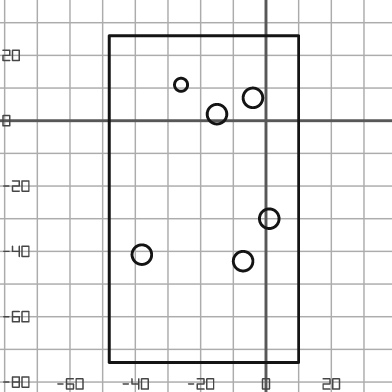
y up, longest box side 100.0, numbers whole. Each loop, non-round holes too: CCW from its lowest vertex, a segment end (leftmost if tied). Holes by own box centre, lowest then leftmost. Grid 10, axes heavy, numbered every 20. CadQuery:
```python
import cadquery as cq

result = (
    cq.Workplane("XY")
    .moveTo(-48.0, -74.0)
    .lineTo(10.0, -74.0)
    .lineTo(10.0, 26.0)
    .lineTo(-48.0, 26.0)
    .close()
    .moveTo(-7.0, -43.0)
    .circle(3.0)
    .moveTo(-38.0, -41.0)
    .circle(3.0)
    .moveTo(1.0, -30.0)
    .circle(3.0)
    .moveTo(-15.0, 2.0)
    .circle(3.0)
    .moveTo(-4.0, 7.0)
    .circle(3.0)
    .moveTo(-26.0, 11.0)
    .circle(2.0)
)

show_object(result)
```